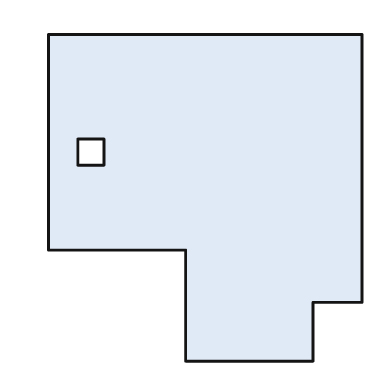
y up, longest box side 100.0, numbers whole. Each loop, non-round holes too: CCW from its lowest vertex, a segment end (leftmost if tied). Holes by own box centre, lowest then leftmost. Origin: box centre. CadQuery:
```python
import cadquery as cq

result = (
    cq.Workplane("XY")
    .moveTo(-6.0, -50.0)
    .lineTo(33.0, -50.0)
    .lineTo(33.0, -32.0)
    .lineTo(48.0, -32.0)
    .lineTo(48.0, 50.0)
    .lineTo(-48.0, 50.0)
    .lineTo(-48.0, -16.0)
    .lineTo(-6.0, -16.0)
    .close()
    .moveTo(-39.0, 10.0)
    .lineTo(-31.0, 10.0)
    .lineTo(-31.0, 18.0)
    .lineTo(-39.0, 18.0)
    .close()
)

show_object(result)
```